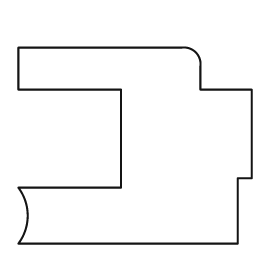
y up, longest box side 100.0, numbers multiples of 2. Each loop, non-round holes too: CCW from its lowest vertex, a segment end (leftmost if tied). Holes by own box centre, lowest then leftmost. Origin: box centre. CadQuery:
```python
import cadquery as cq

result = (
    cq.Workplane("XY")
    .moveTo(-50.0, -42.0)
    .lineTo(44.0, -42.0)
    .lineTo(44.0, -14.0)
    .lineTo(50.0, -14.0)
    .lineTo(50.0, 24.0)
    .lineTo(28.0, 24.0)
    .lineTo(28.0, 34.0)
    .threePointArc((26.0, 40.0), (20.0, 42.0))
    .lineTo(-50.0, 42.0)
    .lineTo(-50.0, 24.0)
    .lineTo(-6.0, 24.0)
    .lineTo(-6.0, -18.0)
    .lineTo(-50.0, -18.0)
    .threePointArc((-46.0, -30.0), (-50.0, -42.0))
    .close()
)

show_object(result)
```